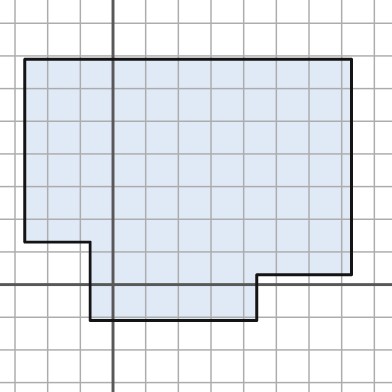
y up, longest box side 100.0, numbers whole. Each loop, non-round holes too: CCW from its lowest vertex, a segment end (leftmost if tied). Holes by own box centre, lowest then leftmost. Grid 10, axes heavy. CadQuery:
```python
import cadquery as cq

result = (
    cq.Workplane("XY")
    .moveTo(-7.0, -11.0)
    .lineTo(44.0, -11.0)
    .lineTo(44.0, 3.0)
    .lineTo(73.0, 3.0)
    .lineTo(73.0, 69.0)
    .lineTo(-27.0, 69.0)
    .lineTo(-27.0, 13.0)
    .lineTo(-7.0, 13.0)
    .close()
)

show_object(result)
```